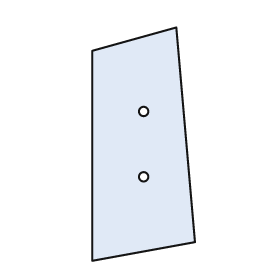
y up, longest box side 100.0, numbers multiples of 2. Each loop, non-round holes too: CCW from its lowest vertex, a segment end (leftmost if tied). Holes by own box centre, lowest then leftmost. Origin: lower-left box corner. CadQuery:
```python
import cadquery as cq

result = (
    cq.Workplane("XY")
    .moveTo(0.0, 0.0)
    .lineTo(44.0, 8.0)
    .lineTo(36.0, 100.0)
    .lineTo(0.0, 90.0)
    .close()
    .moveTo(22.0, 36.0)
    .circle(2.0)
    .moveTo(22.0, 64.0)
    .circle(2.0)
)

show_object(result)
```